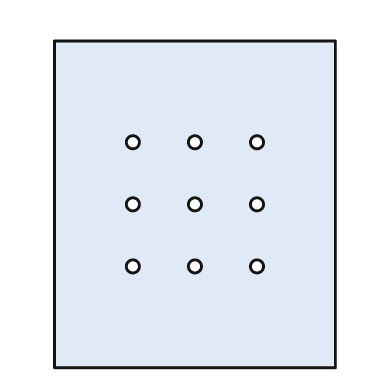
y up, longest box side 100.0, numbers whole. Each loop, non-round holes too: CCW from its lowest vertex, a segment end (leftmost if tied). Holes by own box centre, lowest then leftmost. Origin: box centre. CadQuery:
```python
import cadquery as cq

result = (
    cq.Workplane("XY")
    .moveTo(-43.0, -50.0)
    .lineTo(43.0, -50.0)
    .lineTo(43.0, 50.0)
    .lineTo(-43.0, 50.0)
    .close()
    .moveTo(-19.0, -19.0)
    .circle(2.0)
    .moveTo(0.0, -19.0)
    .circle(2.0)
    .moveTo(19.0, -19.0)
    .circle(2.0)
    .moveTo(-19.0, 0.0)
    .circle(2.0)
    .moveTo(0.0, 0.0)
    .circle(2.0)
    .moveTo(19.0, 0.0)
    .circle(2.0)
    .moveTo(-19.0, 19.0)
    .circle(2.0)
    .moveTo(0.0, 19.0)
    .circle(2.0)
    .moveTo(19.0, 19.0)
    .circle(2.0)
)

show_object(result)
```